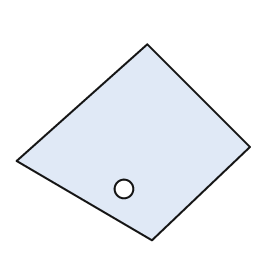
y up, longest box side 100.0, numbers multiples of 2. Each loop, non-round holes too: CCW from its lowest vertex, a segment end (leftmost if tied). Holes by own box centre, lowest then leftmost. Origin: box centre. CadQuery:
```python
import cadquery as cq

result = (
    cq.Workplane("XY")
    .moveTo(8.0, -42.0)
    .lineTo(50.0, -2.0)
    .lineTo(6.0, 42.0)
    .lineTo(-50.0, -8.0)
    .close()
    .moveTo(-4.0, -20.0)
    .circle(4.0)
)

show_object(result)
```